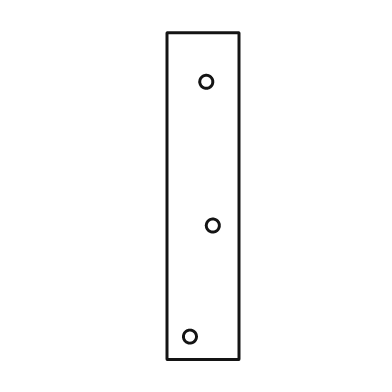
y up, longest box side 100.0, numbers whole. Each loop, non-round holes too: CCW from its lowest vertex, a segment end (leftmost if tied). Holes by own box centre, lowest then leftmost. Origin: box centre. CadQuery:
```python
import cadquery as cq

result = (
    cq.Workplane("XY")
    .moveTo(-11.0, -50.0)
    .lineTo(11.0, -50.0)
    .lineTo(11.0, 50.0)
    .lineTo(-11.0, 50.0)
    .close()
    .moveTo(-4.0, -43.0)
    .circle(2.0)
    .moveTo(3.0, -9.0)
    .circle(2.0)
    .moveTo(1.0, 35.0)
    .circle(2.0)
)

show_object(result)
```